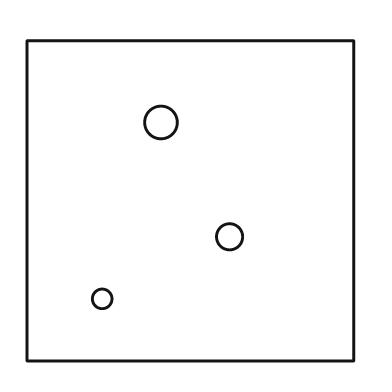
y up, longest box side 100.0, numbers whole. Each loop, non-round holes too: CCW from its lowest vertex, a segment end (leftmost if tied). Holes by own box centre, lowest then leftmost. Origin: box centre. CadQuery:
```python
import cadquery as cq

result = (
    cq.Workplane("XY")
    .moveTo(-50.0, -49.0)
    .lineTo(50.0, -49.0)
    .lineTo(50.0, 49.0)
    .lineTo(-50.0, 49.0)
    .close()
    .moveTo(-27.0, -30.0)
    .circle(3.0)
    .moveTo(12.0, -11.0)
    .circle(4.0)
    .moveTo(-9.0, 24.0)
    .circle(5.0)
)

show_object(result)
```